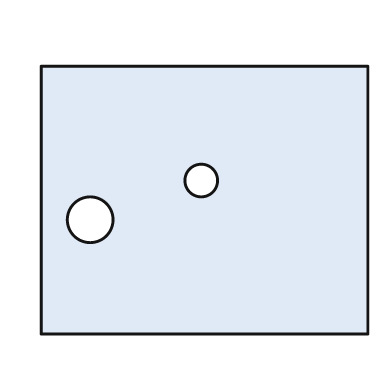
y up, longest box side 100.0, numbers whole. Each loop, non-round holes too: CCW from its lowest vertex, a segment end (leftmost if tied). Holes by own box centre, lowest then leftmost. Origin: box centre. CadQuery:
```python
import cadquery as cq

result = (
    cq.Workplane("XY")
    .moveTo(-50.0, -41.0)
    .lineTo(50.0, -41.0)
    .lineTo(50.0, 41.0)
    .lineTo(-50.0, 41.0)
    .close()
    .moveTo(-35.0, -6.0)
    .circle(7.0)
    .moveTo(-1.0, 6.0)
    .circle(5.0)
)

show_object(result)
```